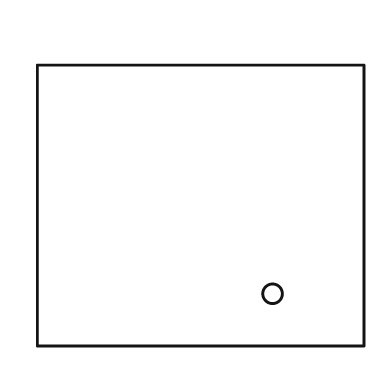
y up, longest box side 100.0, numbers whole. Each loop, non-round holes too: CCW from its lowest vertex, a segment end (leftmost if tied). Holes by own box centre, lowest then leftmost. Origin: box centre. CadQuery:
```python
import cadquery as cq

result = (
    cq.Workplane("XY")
    .moveTo(-50.0, -43.0)
    .lineTo(50.0, -43.0)
    .lineTo(50.0, 43.0)
    .lineTo(-50.0, 43.0)
    .close()
    .moveTo(22.0, -27.0)
    .circle(3.0)
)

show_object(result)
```